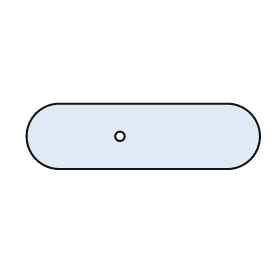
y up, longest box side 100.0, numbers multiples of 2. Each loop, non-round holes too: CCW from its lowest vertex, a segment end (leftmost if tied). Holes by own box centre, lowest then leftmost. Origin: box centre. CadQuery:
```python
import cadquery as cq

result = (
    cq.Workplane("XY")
    .moveTo(-36.0, -14.0)
    .lineTo(36.0, -14.0)
    .threePointArc((50.0, 0.0), (36.0, 14.0))
    .lineTo(-36.0, 14.0)
    .threePointArc((-50.0, 0.0), (-36.0, -14.0))
    .close()
    .moveTo(-10.0, 0.0)
    .circle(2.0)
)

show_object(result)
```